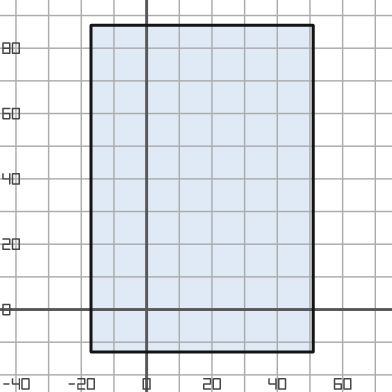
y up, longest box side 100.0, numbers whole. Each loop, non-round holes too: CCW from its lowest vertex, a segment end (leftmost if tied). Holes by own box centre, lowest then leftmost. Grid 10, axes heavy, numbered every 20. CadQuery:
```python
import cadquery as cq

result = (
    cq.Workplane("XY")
    .moveTo(-17.0, -13.0)
    .lineTo(51.0, -13.0)
    .lineTo(51.0, 87.0)
    .lineTo(-17.0, 87.0)
    .close()
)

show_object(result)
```